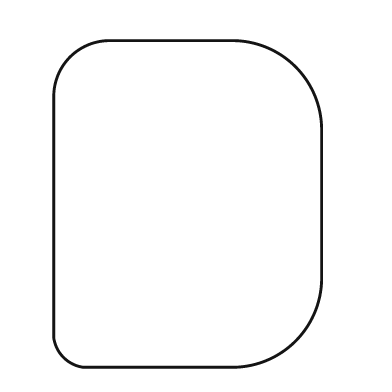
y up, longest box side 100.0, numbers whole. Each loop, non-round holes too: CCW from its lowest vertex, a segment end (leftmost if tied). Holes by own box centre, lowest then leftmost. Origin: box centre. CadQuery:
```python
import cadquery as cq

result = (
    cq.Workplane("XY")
    .moveTo(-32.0, -50.0)
    .lineTo(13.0, -50.0)
    .threePointArc((33.0, -42.0), (41.0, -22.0))
    .lineTo(41.0, 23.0)
    .threePointArc((33.0, 42.0), (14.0, 50.0))
    .lineTo(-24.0, 50.0)
    .threePointArc((-36.0, 45.0), (-41.0, 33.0))
    .lineTo(-41.0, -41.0)
    .threePointArc((-38.0, -47.0), (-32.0, -50.0))
    .close()
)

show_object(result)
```